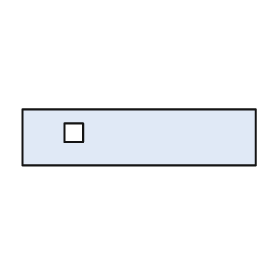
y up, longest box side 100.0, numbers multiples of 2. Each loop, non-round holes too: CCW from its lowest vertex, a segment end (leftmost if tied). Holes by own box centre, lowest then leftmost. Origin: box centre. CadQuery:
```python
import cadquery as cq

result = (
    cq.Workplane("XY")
    .moveTo(-50.0, -12.0)
    .lineTo(50.0, -12.0)
    .lineTo(50.0, 12.0)
    .lineTo(-50.0, 12.0)
    .close()
    .moveTo(-32.0, -2.0)
    .lineTo(-24.0, -2.0)
    .lineTo(-24.0, 6.0)
    .lineTo(-32.0, 6.0)
    .close()
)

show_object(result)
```